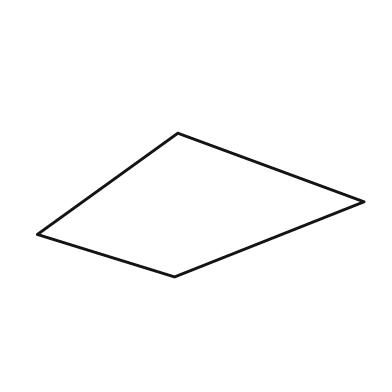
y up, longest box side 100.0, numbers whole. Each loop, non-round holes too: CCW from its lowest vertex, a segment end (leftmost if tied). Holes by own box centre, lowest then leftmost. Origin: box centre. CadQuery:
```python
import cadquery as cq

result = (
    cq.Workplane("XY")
    .moveTo(-8.0, -22.0)
    .lineTo(50.0, 1.0)
    .lineTo(-7.0, 22.0)
    .lineTo(-50.0, -9.0)
    .close()
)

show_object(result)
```